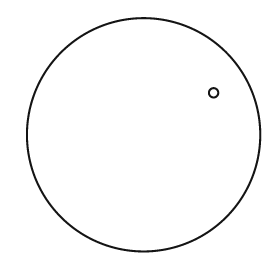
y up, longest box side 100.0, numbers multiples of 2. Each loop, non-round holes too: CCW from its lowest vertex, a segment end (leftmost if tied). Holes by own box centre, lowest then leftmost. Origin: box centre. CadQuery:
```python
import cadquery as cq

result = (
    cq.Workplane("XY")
    .moveTo(0.0, 0.0)
    .circle(50.0)
    .moveTo(30.0, 18.0)
    .circle(2.0)
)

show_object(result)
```